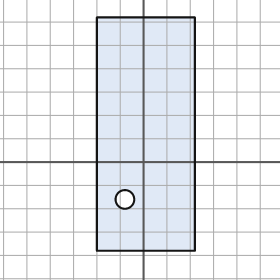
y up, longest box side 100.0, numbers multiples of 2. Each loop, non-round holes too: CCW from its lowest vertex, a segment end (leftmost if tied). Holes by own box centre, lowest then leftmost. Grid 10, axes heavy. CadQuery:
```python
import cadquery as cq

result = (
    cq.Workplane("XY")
    .moveTo(-20.0, -38.0)
    .lineTo(22.0, -38.0)
    .lineTo(22.0, 62.0)
    .lineTo(-20.0, 62.0)
    .close()
    .moveTo(-8.0, -16.0)
    .circle(4.0)
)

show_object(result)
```